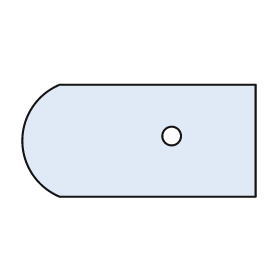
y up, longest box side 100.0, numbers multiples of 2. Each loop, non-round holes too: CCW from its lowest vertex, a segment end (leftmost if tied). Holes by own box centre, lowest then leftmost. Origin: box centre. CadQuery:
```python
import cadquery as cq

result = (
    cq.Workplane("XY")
    .moveTo(-34.0, -24.0)
    .lineTo(50.0, -24.0)
    .lineTo(50.0, 24.0)
    .lineTo(-34.0, 24.0)
    .threePointArc((-50.0, 0.0), (-34.0, -24.0))
    .close()
    .moveTo(14.0, 2.0)
    .circle(4.0)
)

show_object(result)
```